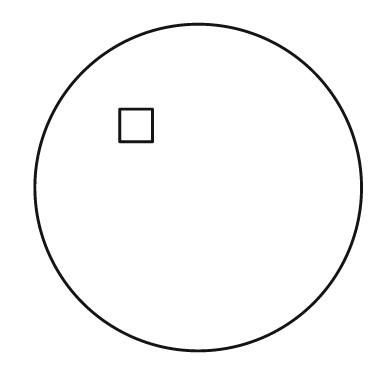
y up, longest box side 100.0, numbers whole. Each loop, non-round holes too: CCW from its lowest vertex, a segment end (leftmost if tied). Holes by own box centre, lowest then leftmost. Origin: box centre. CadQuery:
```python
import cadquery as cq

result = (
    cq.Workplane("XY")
    .moveTo(0.0, 0.0)
    .circle(50.0)
    .moveTo(-24.0, 14.0)
    .lineTo(-14.0, 14.0)
    .lineTo(-14.0, 24.0)
    .lineTo(-24.0, 24.0)
    .close()
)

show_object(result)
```